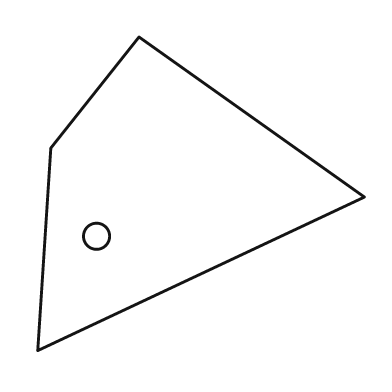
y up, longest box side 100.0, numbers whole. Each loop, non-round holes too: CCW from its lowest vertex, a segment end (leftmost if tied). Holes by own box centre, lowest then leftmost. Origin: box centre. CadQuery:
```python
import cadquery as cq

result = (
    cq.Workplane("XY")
    .moveTo(-50.0, -48.0)
    .lineTo(50.0, -1.0)
    .lineTo(-19.0, 48.0)
    .lineTo(-46.0, 14.0)
    .close()
    .moveTo(-32.0, -13.0)
    .circle(4.0)
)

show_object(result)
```